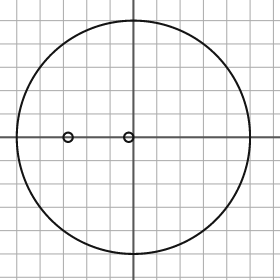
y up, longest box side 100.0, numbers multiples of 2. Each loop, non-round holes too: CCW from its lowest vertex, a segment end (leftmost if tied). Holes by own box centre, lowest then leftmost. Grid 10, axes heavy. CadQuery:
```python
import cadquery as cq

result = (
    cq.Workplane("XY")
    .moveTo(0.0, 0.0)
    .circle(50.0)
    .moveTo(-28.0, 0.0)
    .circle(2.0)
    .moveTo(-2.0, 0.0)
    .circle(2.0)
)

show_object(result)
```